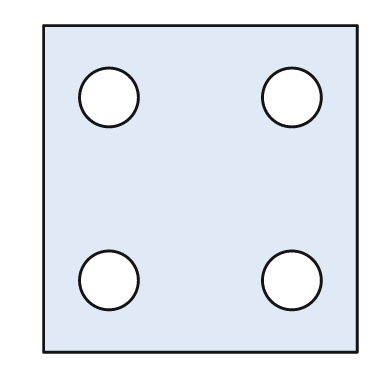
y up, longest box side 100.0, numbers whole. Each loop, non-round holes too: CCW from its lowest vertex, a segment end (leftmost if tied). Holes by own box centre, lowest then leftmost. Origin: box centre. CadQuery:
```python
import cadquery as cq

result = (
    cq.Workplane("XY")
    .moveTo(-48.0, -50.0)
    .lineTo(48.0, -50.0)
    .lineTo(48.0, 50.0)
    .lineTo(-48.0, 50.0)
    .close()
    .moveTo(-28.0, -28.0)
    .circle(9.0)
    .moveTo(28.0, -28.0)
    .circle(9.0)
    .moveTo(-28.0, 28.0)
    .circle(9.0)
    .moveTo(28.0, 28.0)
    .circle(9.0)
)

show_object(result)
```